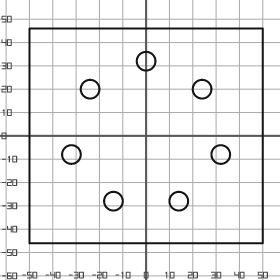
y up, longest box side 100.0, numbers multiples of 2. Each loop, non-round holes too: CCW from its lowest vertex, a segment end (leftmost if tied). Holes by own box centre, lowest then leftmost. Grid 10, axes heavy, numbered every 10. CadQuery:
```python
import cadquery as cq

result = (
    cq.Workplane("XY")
    .moveTo(-50.0, -46.0)
    .lineTo(50.0, -46.0)
    .lineTo(50.0, 46.0)
    .lineTo(-50.0, 46.0)
    .close()
    .moveTo(-14.0, -28.0)
    .circle(4.0)
    .moveTo(14.0, -28.0)
    .circle(4.0)
    .moveTo(-32.0, -8.0)
    .circle(4.0)
    .moveTo(32.0, -8.0)
    .circle(4.0)
    .moveTo(-24.0, 20.0)
    .circle(4.0)
    .moveTo(24.0, 20.0)
    .circle(4.0)
    .moveTo(0.0, 32.0)
    .circle(4.0)
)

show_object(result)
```